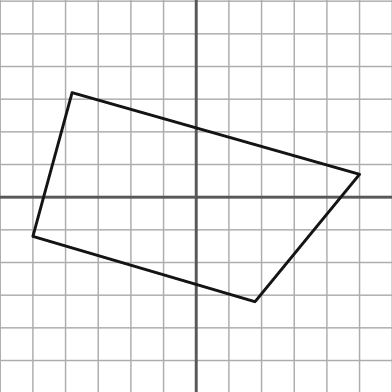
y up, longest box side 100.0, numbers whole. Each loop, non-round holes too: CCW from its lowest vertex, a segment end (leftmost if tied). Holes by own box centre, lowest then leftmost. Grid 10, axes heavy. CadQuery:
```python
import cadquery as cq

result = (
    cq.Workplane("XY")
    .moveTo(18.0, -32.0)
    .lineTo(50.0, 7.0)
    .lineTo(-38.0, 32.0)
    .lineTo(-50.0, -12.0)
    .close()
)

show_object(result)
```